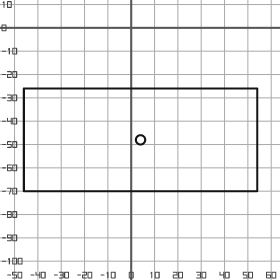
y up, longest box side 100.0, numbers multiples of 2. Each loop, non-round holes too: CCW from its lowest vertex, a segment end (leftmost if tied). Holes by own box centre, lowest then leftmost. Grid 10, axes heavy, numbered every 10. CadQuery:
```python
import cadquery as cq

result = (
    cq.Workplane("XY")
    .moveTo(-46.0, -70.0)
    .lineTo(54.0, -70.0)
    .lineTo(54.0, -26.0)
    .lineTo(-46.0, -26.0)
    .close()
    .moveTo(4.0, -48.0)
    .circle(2.0)
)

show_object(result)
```